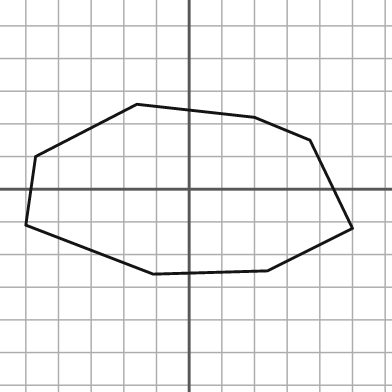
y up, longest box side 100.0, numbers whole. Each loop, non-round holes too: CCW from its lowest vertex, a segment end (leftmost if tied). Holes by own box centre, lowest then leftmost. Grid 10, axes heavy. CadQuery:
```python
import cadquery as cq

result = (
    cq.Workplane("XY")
    .moveTo(-11.0, -26.0)
    .lineTo(24.0, -25.0)
    .lineTo(50.0, -12.0)
    .lineTo(37.0, 15.0)
    .lineTo(20.0, 22.0)
    .lineTo(-16.0, 26.0)
    .lineTo(-47.0, 10.0)
    .lineTo(-50.0, -11.0)
    .close()
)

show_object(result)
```